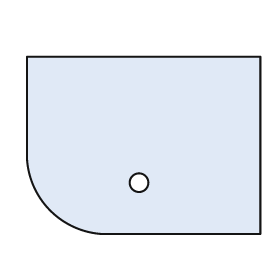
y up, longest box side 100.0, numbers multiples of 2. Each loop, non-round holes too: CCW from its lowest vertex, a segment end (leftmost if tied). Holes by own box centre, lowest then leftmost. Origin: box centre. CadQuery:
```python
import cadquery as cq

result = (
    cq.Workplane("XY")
    .moveTo(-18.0, -38.0)
    .lineTo(50.0, -38.0)
    .lineTo(50.0, 38.0)
    .lineTo(-50.0, 38.0)
    .lineTo(-50.0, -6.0)
    .threePointArc((-40.0, -28.0), (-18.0, -38.0))
    .close()
    .moveTo(-2.0, -16.0)
    .circle(4.0)
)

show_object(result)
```